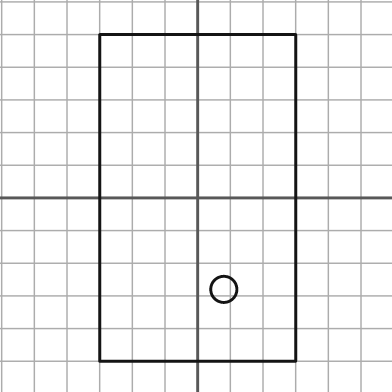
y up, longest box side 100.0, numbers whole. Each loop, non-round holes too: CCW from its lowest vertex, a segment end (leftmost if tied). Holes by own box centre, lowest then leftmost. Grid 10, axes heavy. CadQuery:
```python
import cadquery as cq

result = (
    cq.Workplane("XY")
    .moveTo(-30.0, -50.0)
    .lineTo(30.0, -50.0)
    .lineTo(30.0, 50.0)
    .lineTo(-30.0, 50.0)
    .close()
    .moveTo(8.0, -28.0)
    .circle(4.0)
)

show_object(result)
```